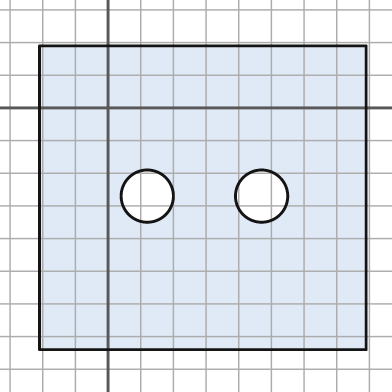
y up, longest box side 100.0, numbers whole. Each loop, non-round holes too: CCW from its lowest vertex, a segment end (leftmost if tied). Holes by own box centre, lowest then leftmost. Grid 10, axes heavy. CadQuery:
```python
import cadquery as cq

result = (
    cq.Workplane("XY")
    .moveTo(-21.0, -74.0)
    .lineTo(79.0, -74.0)
    .lineTo(79.0, 19.0)
    .lineTo(-21.0, 19.0)
    .close()
    .moveTo(12.0, -27.0)
    .circle(8.0)
    .moveTo(47.0, -27.0)
    .circle(8.0)
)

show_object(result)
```